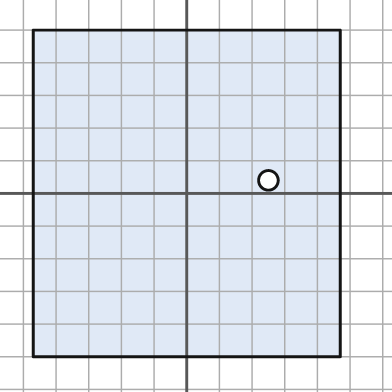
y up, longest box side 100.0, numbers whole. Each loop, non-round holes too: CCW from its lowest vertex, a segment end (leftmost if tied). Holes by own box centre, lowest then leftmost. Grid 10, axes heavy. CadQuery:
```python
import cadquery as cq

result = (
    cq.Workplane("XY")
    .moveTo(-47.0, -50.0)
    .lineTo(47.0, -50.0)
    .lineTo(47.0, 50.0)
    .lineTo(-47.0, 50.0)
    .close()
    .moveTo(25.0, 4.0)
    .circle(3.0)
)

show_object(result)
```